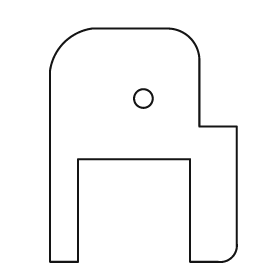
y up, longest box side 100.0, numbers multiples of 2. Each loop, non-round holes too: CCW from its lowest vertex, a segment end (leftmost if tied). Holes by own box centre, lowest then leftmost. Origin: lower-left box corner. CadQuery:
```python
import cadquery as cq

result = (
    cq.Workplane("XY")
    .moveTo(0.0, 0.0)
    .lineTo(12.0, 0.0)
    .lineTo(12.0, 44.0)
    .lineTo(60.0, 44.0)
    .lineTo(60.0, 0.0)
    .lineTo(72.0, 0.0)
    .threePointArc((78.0, 2.0), (80.0, 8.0))
    .lineTo(80.0, 58.0)
    .lineTo(64.0, 58.0)
    .lineTo(64.0, 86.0)
    .threePointArc((60.0, 96.0), (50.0, 100.0))
    .lineTo(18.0, 100.0)
    .threePointArc((6.0, 94.0), (0.0, 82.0))
    .close()
    .moveTo(40.0, 70.0)
    .circle(4.0)
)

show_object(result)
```